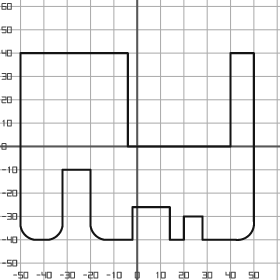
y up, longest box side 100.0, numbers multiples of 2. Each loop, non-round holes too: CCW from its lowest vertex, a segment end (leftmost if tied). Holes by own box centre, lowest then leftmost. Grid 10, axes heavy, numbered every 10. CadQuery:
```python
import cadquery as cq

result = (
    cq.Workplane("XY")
    .moveTo(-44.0, -40.0)
    .lineTo(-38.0, -40.0)
    .threePointArc((-34.0, -38.0), (-32.0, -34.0))
    .lineTo(-32.0, -10.0)
    .lineTo(-20.0, -10.0)
    .lineTo(-20.0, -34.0)
    .threePointArc((-18.0, -38.0), (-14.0, -40.0))
    .lineTo(-2.0, -40.0)
    .lineTo(-2.0, -26.0)
    .lineTo(14.0, -26.0)
    .lineTo(14.0, -40.0)
    .lineTo(20.0, -40.0)
    .lineTo(20.0, -30.0)
    .lineTo(28.0, -30.0)
    .lineTo(28.0, -40.0)
    .lineTo(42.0, -40.0)
    .threePointArc((48.0, -38.0), (50.0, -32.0))
    .lineTo(50.0, 40.0)
    .lineTo(40.0, 40.0)
    .lineTo(40.0, 0.0)
    .lineTo(-4.0, 0.0)
    .lineTo(-4.0, 40.0)
    .lineTo(-50.0, 40.0)
    .lineTo(-50.0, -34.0)
    .threePointArc((-48.0, -38.0), (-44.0, -40.0))
    .close()
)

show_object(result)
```